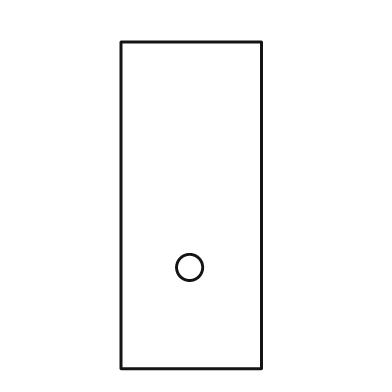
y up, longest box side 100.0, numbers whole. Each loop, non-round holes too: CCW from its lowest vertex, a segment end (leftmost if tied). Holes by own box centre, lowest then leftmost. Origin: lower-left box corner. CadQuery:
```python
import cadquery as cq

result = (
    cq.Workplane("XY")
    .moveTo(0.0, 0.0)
    .lineTo(43.0, 0.0)
    .lineTo(43.0, 100.0)
    .lineTo(0.0, 100.0)
    .close()
    .moveTo(21.0, 31.0)
    .circle(4.0)
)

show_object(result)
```